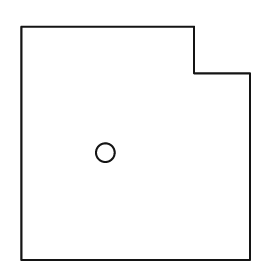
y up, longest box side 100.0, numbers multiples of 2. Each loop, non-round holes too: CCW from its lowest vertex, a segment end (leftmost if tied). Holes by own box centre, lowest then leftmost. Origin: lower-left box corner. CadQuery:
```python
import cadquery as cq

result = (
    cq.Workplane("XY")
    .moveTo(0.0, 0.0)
    .lineTo(98.0, 0.0)
    .lineTo(98.0, 80.0)
    .lineTo(74.0, 80.0)
    .lineTo(74.0, 100.0)
    .lineTo(0.0, 100.0)
    .close()
    .moveTo(36.0, 46.0)
    .circle(4.0)
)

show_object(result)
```